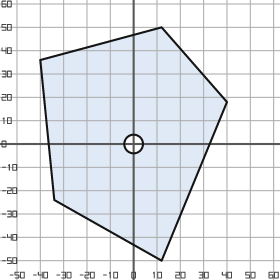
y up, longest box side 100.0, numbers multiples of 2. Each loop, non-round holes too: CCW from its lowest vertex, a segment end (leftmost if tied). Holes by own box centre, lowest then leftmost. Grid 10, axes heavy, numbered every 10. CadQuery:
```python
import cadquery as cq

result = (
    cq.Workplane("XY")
    .moveTo(12.0, -50.0)
    .lineTo(40.0, 18.0)
    .lineTo(12.0, 50.0)
    .lineTo(-40.0, 36.0)
    .lineTo(-34.0, -24.0)
    .close()
    .moveTo(0.0, 0.0)
    .circle(4.0)
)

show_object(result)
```